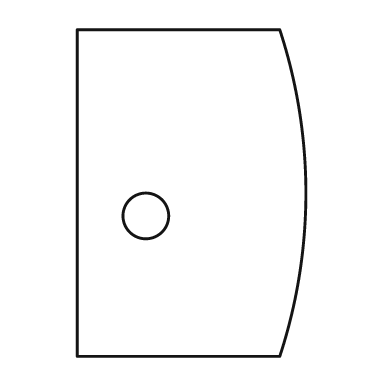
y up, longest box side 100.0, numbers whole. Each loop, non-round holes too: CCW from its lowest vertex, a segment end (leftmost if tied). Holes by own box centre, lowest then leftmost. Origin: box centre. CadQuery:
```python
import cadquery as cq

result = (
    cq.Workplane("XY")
    .moveTo(-35.0, -50.0)
    .lineTo(27.0, -50.0)
    .threePointArc((35.0, 0.0), (27.0, 50.0))
    .lineTo(-35.0, 50.0)
    .close()
    .moveTo(-14.0, -7.0)
    .circle(7.0)
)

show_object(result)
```